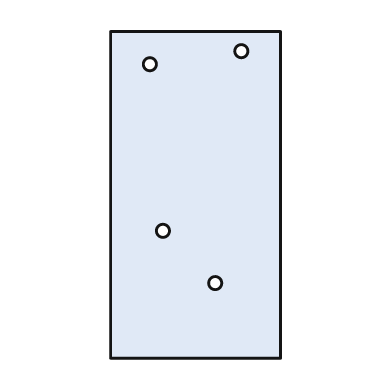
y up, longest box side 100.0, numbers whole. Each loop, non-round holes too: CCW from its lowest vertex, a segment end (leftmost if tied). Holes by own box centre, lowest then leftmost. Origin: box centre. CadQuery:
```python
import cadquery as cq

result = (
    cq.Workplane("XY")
    .moveTo(-26.0, -50.0)
    .lineTo(26.0, -50.0)
    .lineTo(26.0, 50.0)
    .lineTo(-26.0, 50.0)
    .close()
    .moveTo(6.0, -27.0)
    .circle(2.0)
    .moveTo(-10.0, -11.0)
    .circle(2.0)
    .moveTo(-14.0, 40.0)
    .circle(2.0)
    .moveTo(14.0, 44.0)
    .circle(2.0)
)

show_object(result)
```